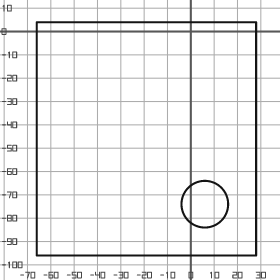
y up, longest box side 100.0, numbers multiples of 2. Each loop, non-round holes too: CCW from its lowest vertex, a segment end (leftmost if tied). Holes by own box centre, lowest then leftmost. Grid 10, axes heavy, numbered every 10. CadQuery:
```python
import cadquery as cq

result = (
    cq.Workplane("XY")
    .moveTo(-66.0, -96.0)
    .lineTo(28.0, -96.0)
    .lineTo(28.0, 4.0)
    .lineTo(-66.0, 4.0)
    .close()
    .moveTo(6.0, -74.0)
    .circle(10.0)
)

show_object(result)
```